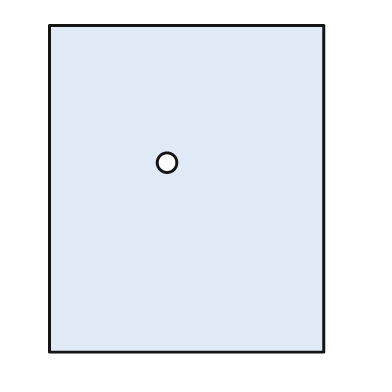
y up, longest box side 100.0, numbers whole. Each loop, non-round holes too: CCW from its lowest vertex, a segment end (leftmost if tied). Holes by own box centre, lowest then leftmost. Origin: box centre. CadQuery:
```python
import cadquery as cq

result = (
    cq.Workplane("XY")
    .moveTo(-42.0, -50.0)
    .lineTo(42.0, -50.0)
    .lineTo(42.0, 50.0)
    .lineTo(-42.0, 50.0)
    .close()
    .moveTo(-6.0, 8.0)
    .circle(3.0)
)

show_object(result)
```